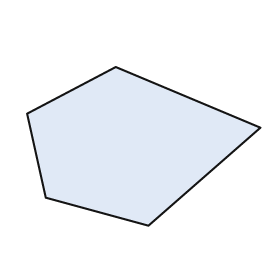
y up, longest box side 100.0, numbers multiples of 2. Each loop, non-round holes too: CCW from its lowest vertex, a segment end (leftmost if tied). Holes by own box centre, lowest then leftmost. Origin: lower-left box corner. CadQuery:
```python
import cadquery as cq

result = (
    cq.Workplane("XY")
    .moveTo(52.0, 0.0)
    .lineTo(100.0, 42.0)
    .lineTo(38.0, 68.0)
    .lineTo(0.0, 48.0)
    .lineTo(8.0, 12.0)
    .close()
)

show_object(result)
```